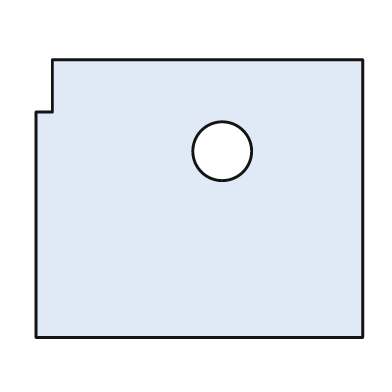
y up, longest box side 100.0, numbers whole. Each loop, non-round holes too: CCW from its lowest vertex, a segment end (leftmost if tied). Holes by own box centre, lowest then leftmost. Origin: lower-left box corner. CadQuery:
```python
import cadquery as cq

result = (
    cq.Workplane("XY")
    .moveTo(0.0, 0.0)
    .lineTo(100.0, 0.0)
    .lineTo(100.0, 85.0)
    .lineTo(5.0, 85.0)
    .lineTo(5.0, 69.0)
    .lineTo(0.0, 69.0)
    .close()
    .moveTo(57.0, 57.0)
    .circle(9.0)
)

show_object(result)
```